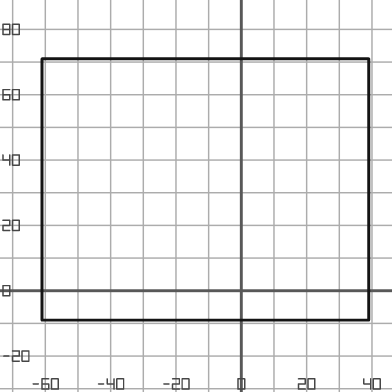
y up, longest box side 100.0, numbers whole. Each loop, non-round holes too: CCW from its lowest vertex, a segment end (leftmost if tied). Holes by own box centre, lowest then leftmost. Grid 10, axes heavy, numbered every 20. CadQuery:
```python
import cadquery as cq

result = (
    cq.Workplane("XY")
    .moveTo(-61.0, -9.0)
    .lineTo(39.0, -9.0)
    .lineTo(39.0, 71.0)
    .lineTo(-61.0, 71.0)
    .close()
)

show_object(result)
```